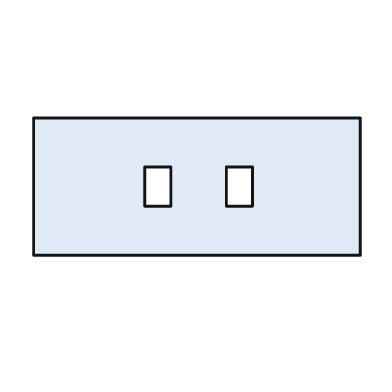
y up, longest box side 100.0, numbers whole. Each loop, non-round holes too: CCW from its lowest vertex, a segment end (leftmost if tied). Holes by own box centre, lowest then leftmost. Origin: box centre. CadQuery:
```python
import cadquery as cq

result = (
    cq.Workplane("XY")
    .moveTo(-50.0, -21.0)
    .lineTo(50.0, -21.0)
    .lineTo(50.0, 21.0)
    .lineTo(-50.0, 21.0)
    .close()
    .moveTo(-16.0, -6.0)
    .lineTo(-8.0, -6.0)
    .lineTo(-8.0, 6.0)
    .lineTo(-16.0, 6.0)
    .close()
    .moveTo(9.0, -6.0)
    .lineTo(17.0, -6.0)
    .lineTo(17.0, 6.0)
    .lineTo(9.0, 6.0)
    .close()
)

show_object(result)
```